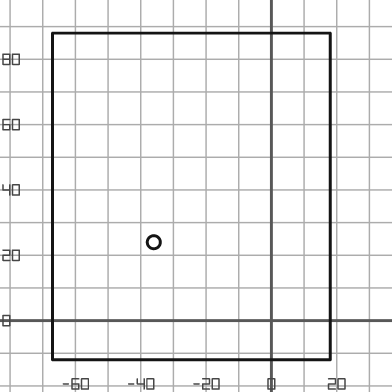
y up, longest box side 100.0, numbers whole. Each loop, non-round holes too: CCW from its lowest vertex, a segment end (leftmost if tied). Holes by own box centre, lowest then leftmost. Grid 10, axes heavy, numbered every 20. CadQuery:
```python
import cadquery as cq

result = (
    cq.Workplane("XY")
    .moveTo(-67.0, -12.0)
    .lineTo(18.0, -12.0)
    .lineTo(18.0, 88.0)
    .lineTo(-67.0, 88.0)
    .close()
    .moveTo(-36.0, 24.0)
    .circle(2.0)
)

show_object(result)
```